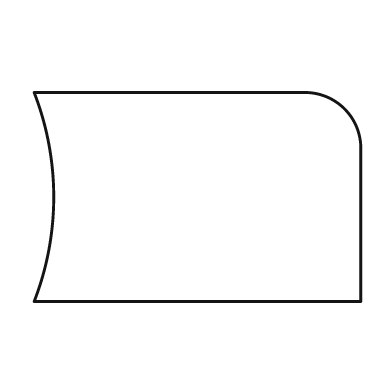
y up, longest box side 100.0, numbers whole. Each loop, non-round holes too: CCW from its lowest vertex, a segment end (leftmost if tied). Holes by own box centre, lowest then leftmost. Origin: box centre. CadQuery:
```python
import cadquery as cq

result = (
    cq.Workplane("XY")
    .moveTo(-50.0, -32.0)
    .lineTo(50.0, -32.0)
    .lineTo(50.0, 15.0)
    .threePointArc((45.0, 27.0), (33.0, 32.0))
    .lineTo(-50.0, 32.0)
    .threePointArc((-44.0, 0.0), (-50.0, -32.0))
    .close()
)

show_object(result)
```